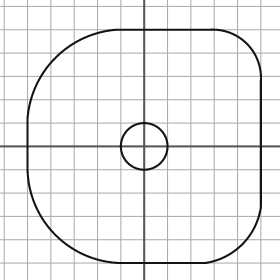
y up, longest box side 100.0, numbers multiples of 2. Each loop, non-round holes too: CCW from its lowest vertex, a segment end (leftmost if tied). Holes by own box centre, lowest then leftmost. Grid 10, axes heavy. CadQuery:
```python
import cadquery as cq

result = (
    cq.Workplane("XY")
    .moveTo(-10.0, -50.0)
    .lineTo(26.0, -50.0)
    .threePointArc((42.0, -42.0), (50.0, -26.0))
    .lineTo(50.0, 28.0)
    .threePointArc((44.0, 44.0), (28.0, 50.0))
    .lineTo(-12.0, 50.0)
    .threePointArc((-38.0, 38.0), (-50.0, 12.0))
    .lineTo(-50.0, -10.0)
    .threePointArc((-38.0, -38.0), (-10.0, -50.0))
    .close()
    .moveTo(0.0, 0.0)
    .circle(10.0)
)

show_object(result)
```